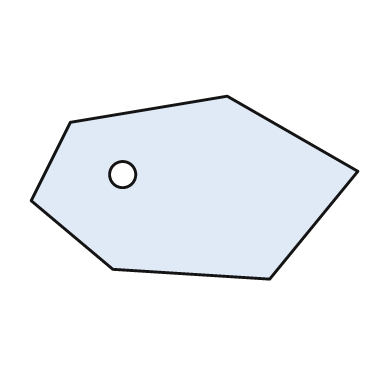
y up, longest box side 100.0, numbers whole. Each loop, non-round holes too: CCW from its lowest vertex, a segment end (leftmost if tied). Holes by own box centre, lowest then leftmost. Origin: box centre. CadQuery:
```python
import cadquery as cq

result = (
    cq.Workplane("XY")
    .moveTo(23.0, -28.0)
    .lineTo(50.0, 5.0)
    .lineTo(10.0, 28.0)
    .lineTo(-38.0, 20.0)
    .lineTo(-50.0, -4.0)
    .lineTo(-25.0, -25.0)
    .close()
    .moveTo(-22.0, 4.0)
    .circle(4.0)
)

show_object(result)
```